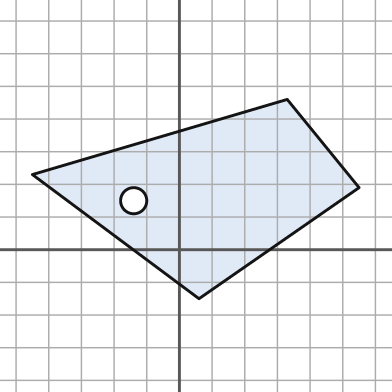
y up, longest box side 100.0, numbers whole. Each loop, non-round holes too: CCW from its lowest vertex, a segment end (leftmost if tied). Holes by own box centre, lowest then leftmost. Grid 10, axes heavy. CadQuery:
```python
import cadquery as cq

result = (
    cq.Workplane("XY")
    .moveTo(6.0, -15.0)
    .lineTo(55.0, 19.0)
    .lineTo(33.0, 46.0)
    .lineTo(-45.0, 23.0)
    .close()
    .moveTo(-14.0, 15.0)
    .circle(4.0)
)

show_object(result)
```